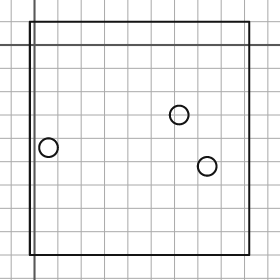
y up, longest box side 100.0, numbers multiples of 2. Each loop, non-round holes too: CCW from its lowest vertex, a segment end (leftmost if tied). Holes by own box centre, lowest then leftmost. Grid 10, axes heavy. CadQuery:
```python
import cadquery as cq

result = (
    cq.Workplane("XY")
    .moveTo(-2.0, -90.0)
    .lineTo(92.0, -90.0)
    .lineTo(92.0, 10.0)
    .lineTo(-2.0, 10.0)
    .close()
    .moveTo(74.0, -52.0)
    .circle(4.0)
    .moveTo(6.0, -44.0)
    .circle(4.0)
    .moveTo(62.0, -30.0)
    .circle(4.0)
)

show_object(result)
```